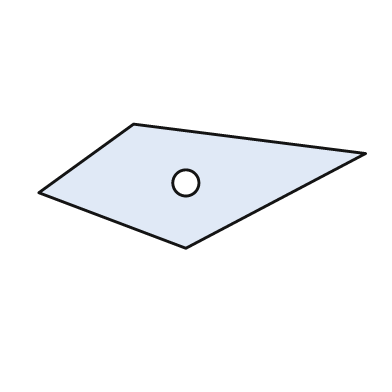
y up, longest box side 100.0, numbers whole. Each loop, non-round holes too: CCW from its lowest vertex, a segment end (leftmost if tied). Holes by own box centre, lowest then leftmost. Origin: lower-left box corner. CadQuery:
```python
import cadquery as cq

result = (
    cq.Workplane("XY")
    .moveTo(45.0, 0.0)
    .lineTo(100.0, 29.0)
    .lineTo(29.0, 38.0)
    .lineTo(0.0, 17.0)
    .close()
    .moveTo(45.0, 20.0)
    .circle(4.0)
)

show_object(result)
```